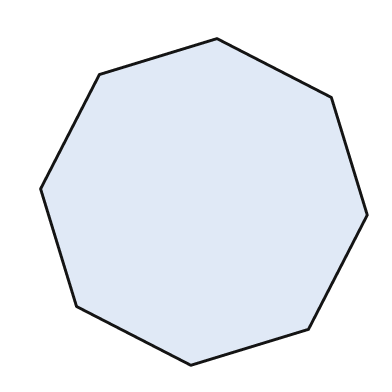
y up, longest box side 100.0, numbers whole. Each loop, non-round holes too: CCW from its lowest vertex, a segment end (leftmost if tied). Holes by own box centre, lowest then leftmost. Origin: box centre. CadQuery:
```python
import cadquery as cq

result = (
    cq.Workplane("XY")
    .moveTo(-4.0, -50.0)
    .lineTo(32.0, -39.0)
    .lineTo(50.0, -4.0)
    .lineTo(39.0, 32.0)
    .lineTo(4.0, 50.0)
    .lineTo(-32.0, 39.0)
    .lineTo(-50.0, 4.0)
    .lineTo(-39.0, -32.0)
    .close()
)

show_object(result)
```